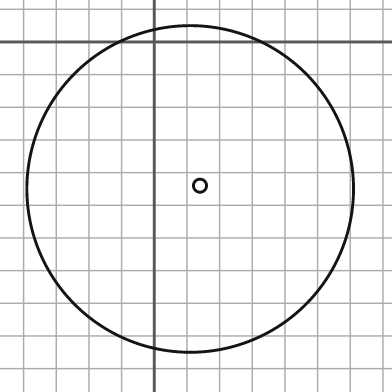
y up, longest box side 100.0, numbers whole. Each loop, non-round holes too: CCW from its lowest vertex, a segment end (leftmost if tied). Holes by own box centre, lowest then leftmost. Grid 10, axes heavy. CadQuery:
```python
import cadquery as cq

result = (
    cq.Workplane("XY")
    .moveTo(11.0, -45.0)
    .circle(50.0)
    .moveTo(14.0, -44.0)
    .circle(2.0)
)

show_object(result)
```